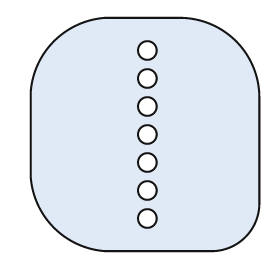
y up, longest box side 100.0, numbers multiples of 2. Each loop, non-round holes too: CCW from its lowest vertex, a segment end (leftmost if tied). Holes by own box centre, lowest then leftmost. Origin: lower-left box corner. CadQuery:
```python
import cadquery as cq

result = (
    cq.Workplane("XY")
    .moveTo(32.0, 0.0)
    .lineTo(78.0, 0.0)
    .threePointArc((92.0, 6.0), (98.0, 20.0))
    .lineTo(98.0, 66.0)
    .threePointArc((88.0, 90.0), (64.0, 100.0))
    .lineTo(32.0, 100.0)
    .threePointArc((10.0, 90.0), (0.0, 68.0))
    .lineTo(0.0, 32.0)
    .threePointArc((10.0, 10.0), (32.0, 0.0))
    .close()
    .moveTo(50.0, 14.0)
    .circle(4.0)
    .moveTo(50.0, 26.0)
    .circle(4.0)
    .moveTo(50.0, 38.0)
    .circle(4.0)
    .moveTo(50.0, 50.0)
    .circle(4.0)
    .moveTo(50.0, 62.0)
    .circle(4.0)
    .moveTo(50.0, 74.0)
    .circle(4.0)
    .moveTo(50.0, 86.0)
    .circle(4.0)
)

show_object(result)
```